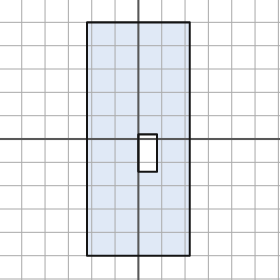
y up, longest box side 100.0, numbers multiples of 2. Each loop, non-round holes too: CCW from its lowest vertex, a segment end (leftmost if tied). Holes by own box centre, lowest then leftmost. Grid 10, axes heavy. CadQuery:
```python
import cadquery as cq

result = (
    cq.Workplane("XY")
    .moveTo(-22.0, -50.0)
    .lineTo(22.0, -50.0)
    .lineTo(22.0, 50.0)
    .lineTo(-22.0, 50.0)
    .close()
    .moveTo(0.0, -14.0)
    .lineTo(8.0, -14.0)
    .lineTo(8.0, 2.0)
    .lineTo(0.0, 2.0)
    .close()
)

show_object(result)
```